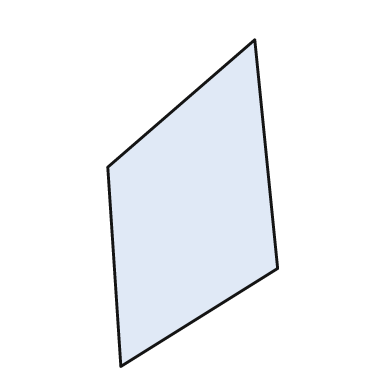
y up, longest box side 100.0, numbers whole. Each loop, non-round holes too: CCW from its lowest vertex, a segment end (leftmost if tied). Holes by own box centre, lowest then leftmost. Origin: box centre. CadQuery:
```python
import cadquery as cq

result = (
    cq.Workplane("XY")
    .moveTo(-22.0, -50.0)
    .lineTo(26.0, -20.0)
    .lineTo(19.0, 50.0)
    .lineTo(-26.0, 11.0)
    .close()
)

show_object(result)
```